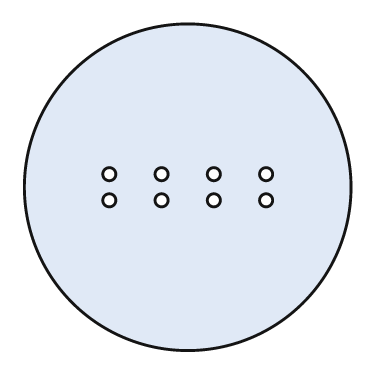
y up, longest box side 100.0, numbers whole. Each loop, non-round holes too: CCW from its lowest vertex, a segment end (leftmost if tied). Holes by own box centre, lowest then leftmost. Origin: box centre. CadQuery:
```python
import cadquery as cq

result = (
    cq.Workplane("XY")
    .moveTo(0.0, 0.0)
    .circle(50.0)
    .moveTo(-24.0, -4.0)
    .circle(2.0)
    .moveTo(-8.0, -4.0)
    .circle(2.0)
    .moveTo(8.0, -4.0)
    .circle(2.0)
    .moveTo(24.0, -4.0)
    .circle(2.0)
    .moveTo(-24.0, 4.0)
    .circle(2.0)
    .moveTo(-8.0, 4.0)
    .circle(2.0)
    .moveTo(8.0, 4.0)
    .circle(2.0)
    .moveTo(24.0, 4.0)
    .circle(2.0)
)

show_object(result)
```